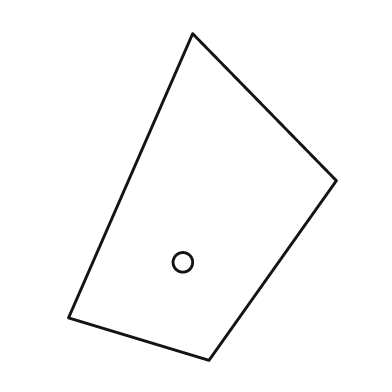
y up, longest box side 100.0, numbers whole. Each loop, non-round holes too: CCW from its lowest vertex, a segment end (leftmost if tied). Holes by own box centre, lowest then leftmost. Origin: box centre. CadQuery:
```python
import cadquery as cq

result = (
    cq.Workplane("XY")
    .moveTo(2.0, -50.0)
    .lineTo(41.0, 5.0)
    .lineTo(-3.0, 50.0)
    .lineTo(-41.0, -37.0)
    .close()
    .moveTo(-6.0, -20.0)
    .circle(3.0)
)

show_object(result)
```